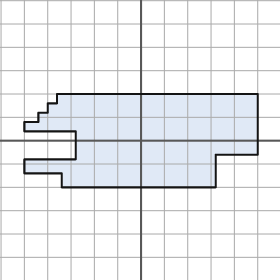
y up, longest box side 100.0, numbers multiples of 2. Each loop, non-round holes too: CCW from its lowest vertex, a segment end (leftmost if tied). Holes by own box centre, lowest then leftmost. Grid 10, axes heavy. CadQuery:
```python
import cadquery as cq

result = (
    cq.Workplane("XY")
    .moveTo(-34.0, -20.0)
    .lineTo(32.0, -20.0)
    .lineTo(32.0, -6.0)
    .lineTo(50.0, -6.0)
    .lineTo(50.0, 20.0)
    .lineTo(-36.0, 20.0)
    .lineTo(-36.0, 16.0)
    .lineTo(-40.0, 16.0)
    .lineTo(-40.0, 12.0)
    .lineTo(-44.0, 12.0)
    .lineTo(-44.0, 8.0)
    .lineTo(-50.0, 8.0)
    .lineTo(-50.0, 4.0)
    .lineTo(-28.0, 4.0)
    .lineTo(-28.0, -8.0)
    .lineTo(-50.0, -8.0)
    .lineTo(-50.0, -14.0)
    .lineTo(-34.0, -14.0)
    .close()
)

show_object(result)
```